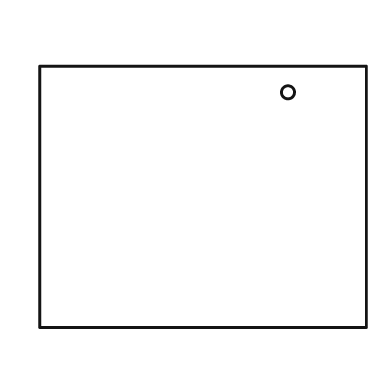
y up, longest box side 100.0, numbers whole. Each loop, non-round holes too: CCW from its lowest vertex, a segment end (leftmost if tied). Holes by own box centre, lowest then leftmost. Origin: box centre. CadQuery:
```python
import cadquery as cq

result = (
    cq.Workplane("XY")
    .moveTo(-50.0, -40.0)
    .lineTo(50.0, -40.0)
    .lineTo(50.0, 40.0)
    .lineTo(-50.0, 40.0)
    .close()
    .moveTo(26.0, 32.0)
    .circle(2.0)
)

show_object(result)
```